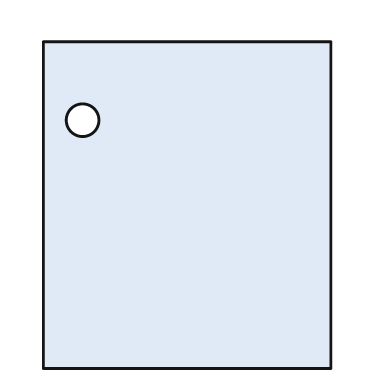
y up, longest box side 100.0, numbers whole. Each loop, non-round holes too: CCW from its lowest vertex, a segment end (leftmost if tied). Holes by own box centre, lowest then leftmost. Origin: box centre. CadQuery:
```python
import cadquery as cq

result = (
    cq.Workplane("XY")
    .moveTo(-44.0, -50.0)
    .lineTo(44.0, -50.0)
    .lineTo(44.0, 50.0)
    .lineTo(-44.0, 50.0)
    .close()
    .moveTo(-32.0, 26.0)
    .circle(5.0)
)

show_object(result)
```